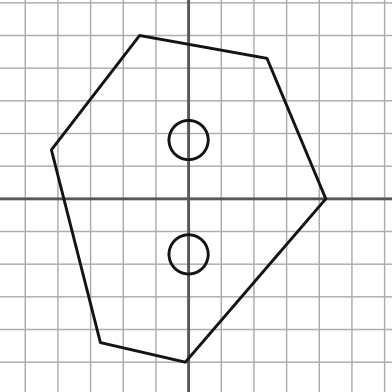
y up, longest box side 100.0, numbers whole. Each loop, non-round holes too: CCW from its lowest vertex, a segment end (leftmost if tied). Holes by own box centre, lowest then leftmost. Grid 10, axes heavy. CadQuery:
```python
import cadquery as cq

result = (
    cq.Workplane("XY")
    .moveTo(-1.0, -50.0)
    .lineTo(42.0, 0.0)
    .lineTo(24.0, 43.0)
    .lineTo(-15.0, 50.0)
    .lineTo(-42.0, 15.0)
    .lineTo(-27.0, -44.0)
    .close()
    .moveTo(0.0, -17.0)
    .circle(6.0)
    .moveTo(0.0, 18.0)
    .circle(6.0)
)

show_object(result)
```